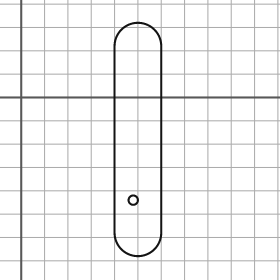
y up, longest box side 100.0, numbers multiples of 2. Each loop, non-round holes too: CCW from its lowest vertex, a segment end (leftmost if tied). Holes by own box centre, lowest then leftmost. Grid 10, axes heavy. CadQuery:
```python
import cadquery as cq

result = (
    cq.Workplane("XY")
    .moveTo(40.0, -58.0)
    .threePointArc((50.0, -68.0), (60.0, -58.0))
    .lineTo(60.0, 22.0)
    .threePointArc((50.0, 32.0), (40.0, 22.0))
    .close()
    .moveTo(48.0, -44.0)
    .circle(2.0)
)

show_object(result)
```